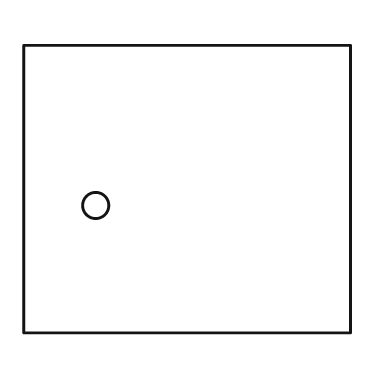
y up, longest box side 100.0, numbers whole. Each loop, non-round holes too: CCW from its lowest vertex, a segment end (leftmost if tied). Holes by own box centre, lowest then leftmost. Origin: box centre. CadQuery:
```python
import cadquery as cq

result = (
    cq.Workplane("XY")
    .moveTo(-50.0, -44.0)
    .lineTo(50.0, -44.0)
    .lineTo(50.0, 44.0)
    .lineTo(-50.0, 44.0)
    .close()
    .moveTo(-28.0, -5.0)
    .circle(4.0)
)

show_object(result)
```